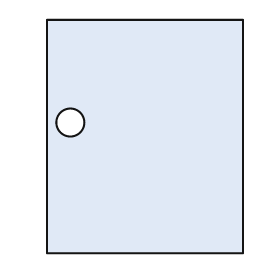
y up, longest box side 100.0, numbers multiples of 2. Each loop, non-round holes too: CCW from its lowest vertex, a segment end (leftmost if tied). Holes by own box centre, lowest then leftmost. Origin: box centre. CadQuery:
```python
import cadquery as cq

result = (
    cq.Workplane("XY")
    .moveTo(-42.0, -50.0)
    .lineTo(42.0, -50.0)
    .lineTo(42.0, 50.0)
    .lineTo(-42.0, 50.0)
    .close()
    .moveTo(-32.0, 6.0)
    .circle(6.0)
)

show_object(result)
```